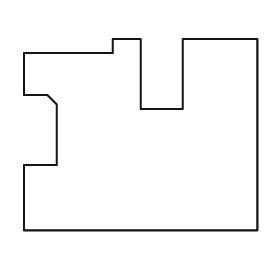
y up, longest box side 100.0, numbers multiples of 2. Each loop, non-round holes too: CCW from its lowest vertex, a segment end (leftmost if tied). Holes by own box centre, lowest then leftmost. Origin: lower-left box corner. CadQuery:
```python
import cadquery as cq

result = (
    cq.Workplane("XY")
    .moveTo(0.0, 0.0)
    .lineTo(100.0, 0.0)
    .lineTo(100.0, 82.0)
    .lineTo(68.0, 82.0)
    .lineTo(68.0, 52.0)
    .lineTo(50.0, 52.0)
    .lineTo(50.0, 82.0)
    .lineTo(38.0, 82.0)
    .lineTo(38.0, 76.0)
    .lineTo(0.0, 76.0)
    .lineTo(0.0, 58.0)
    .lineTo(10.0, 58.0)
    .lineTo(14.0, 54.0)
    .lineTo(14.0, 28.0)
    .lineTo(0.0, 28.0)
    .close()
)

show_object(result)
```